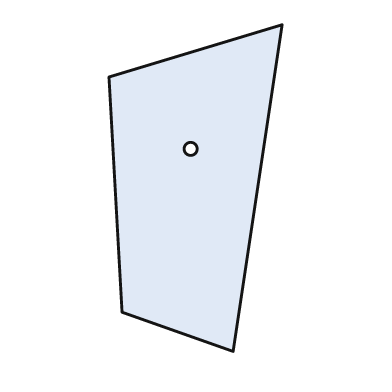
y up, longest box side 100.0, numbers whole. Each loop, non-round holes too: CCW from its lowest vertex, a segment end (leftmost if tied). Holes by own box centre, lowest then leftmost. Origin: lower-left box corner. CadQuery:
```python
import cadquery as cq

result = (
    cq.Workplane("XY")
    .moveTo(38.0, 0.0)
    .lineTo(53.0, 100.0)
    .lineTo(0.0, 84.0)
    .lineTo(4.0, 12.0)
    .close()
    .moveTo(25.0, 62.0)
    .circle(2.0)
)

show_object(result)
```